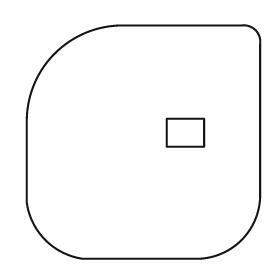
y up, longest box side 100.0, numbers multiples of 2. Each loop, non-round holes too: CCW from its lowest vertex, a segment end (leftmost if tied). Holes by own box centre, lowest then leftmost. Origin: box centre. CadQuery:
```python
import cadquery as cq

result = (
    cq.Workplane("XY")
    .moveTo(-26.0, -50.0)
    .lineTo(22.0, -50.0)
    .threePointArc((42.0, -42.0), (50.0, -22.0))
    .lineTo(50.0, 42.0)
    .threePointArc((48.0, 48.0), (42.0, 50.0))
    .lineTo(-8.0, 50.0)
    .threePointArc((-38.0, 38.0), (-50.0, 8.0))
    .lineTo(-50.0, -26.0)
    .threePointArc((-42.0, -42.0), (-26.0, -50.0))
    .close()
    .moveTo(10.0, -2.0)
    .lineTo(26.0, -2.0)
    .lineTo(26.0, 10.0)
    .lineTo(10.0, 10.0)
    .close()
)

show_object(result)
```